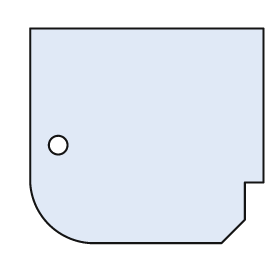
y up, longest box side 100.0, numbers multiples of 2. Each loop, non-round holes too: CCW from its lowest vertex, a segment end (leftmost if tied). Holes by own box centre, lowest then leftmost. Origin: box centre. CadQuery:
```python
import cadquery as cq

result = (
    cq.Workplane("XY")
    .moveTo(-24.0, -46.0)
    .lineTo(32.0, -46.0)
    .lineTo(42.0, -36.0)
    .lineTo(42.0, -20.0)
    .lineTo(50.0, -20.0)
    .lineTo(50.0, 46.0)
    .lineTo(-50.0, 46.0)
    .lineTo(-50.0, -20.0)
    .threePointArc((-42.0, -38.0), (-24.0, -46.0))
    .close()
    .moveTo(-38.0, -4.0)
    .circle(4.0)
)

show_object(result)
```